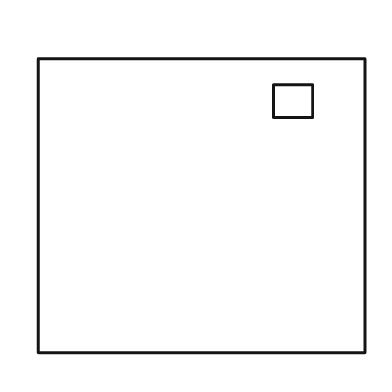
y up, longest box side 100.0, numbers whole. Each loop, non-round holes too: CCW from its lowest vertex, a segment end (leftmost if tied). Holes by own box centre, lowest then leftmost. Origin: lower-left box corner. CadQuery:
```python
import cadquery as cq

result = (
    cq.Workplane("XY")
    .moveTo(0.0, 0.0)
    .lineTo(100.0, 0.0)
    .lineTo(100.0, 90.0)
    .lineTo(0.0, 90.0)
    .close()
    .moveTo(72.0, 72.0)
    .lineTo(84.0, 72.0)
    .lineTo(84.0, 82.0)
    .lineTo(72.0, 82.0)
    .close()
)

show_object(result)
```